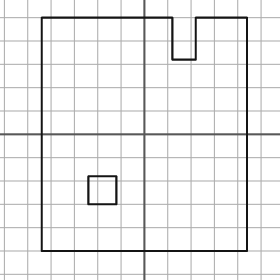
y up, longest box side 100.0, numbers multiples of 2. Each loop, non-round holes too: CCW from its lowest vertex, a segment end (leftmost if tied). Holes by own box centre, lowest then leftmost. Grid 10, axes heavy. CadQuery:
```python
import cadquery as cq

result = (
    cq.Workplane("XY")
    .moveTo(-44.0, -50.0)
    .lineTo(44.0, -50.0)
    .lineTo(44.0, 50.0)
    .lineTo(22.0, 50.0)
    .lineTo(22.0, 32.0)
    .lineTo(12.0, 32.0)
    .lineTo(12.0, 50.0)
    .lineTo(-44.0, 50.0)
    .close()
    .moveTo(-24.0, -30.0)
    .lineTo(-12.0, -30.0)
    .lineTo(-12.0, -18.0)
    .lineTo(-24.0, -18.0)
    .close()
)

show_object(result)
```